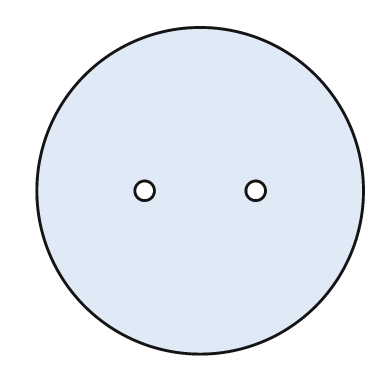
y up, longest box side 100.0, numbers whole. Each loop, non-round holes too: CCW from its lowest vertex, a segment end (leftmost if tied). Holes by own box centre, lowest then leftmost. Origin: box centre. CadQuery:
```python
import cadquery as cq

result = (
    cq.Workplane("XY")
    .moveTo(0.0, 0.0)
    .circle(50.0)
    .moveTo(-17.0, 0.0)
    .circle(3.0)
    .moveTo(17.0, 0.0)
    .circle(3.0)
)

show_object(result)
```